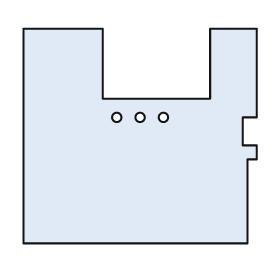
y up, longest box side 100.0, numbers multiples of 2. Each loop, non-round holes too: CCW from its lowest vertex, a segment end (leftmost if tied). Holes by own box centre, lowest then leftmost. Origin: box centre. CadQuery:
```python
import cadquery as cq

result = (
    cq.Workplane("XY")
    .moveTo(-50.0, -46.0)
    .lineTo(46.0, -46.0)
    .lineTo(46.0, -10.0)
    .lineTo(50.0, -10.0)
    .lineTo(50.0, -4.0)
    .lineTo(44.0, -4.0)
    .lineTo(44.0, 8.0)
    .lineTo(50.0, 8.0)
    .lineTo(50.0, 46.0)
    .lineTo(30.0, 46.0)
    .lineTo(30.0, 16.0)
    .lineTo(-16.0, 16.0)
    .lineTo(-16.0, 46.0)
    .lineTo(-50.0, 46.0)
    .close()
    .moveTo(-10.0, 8.0)
    .circle(2.0)
    .moveTo(0.0, 8.0)
    .circle(2.0)
    .moveTo(10.0, 8.0)
    .circle(2.0)
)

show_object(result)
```